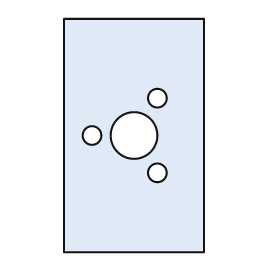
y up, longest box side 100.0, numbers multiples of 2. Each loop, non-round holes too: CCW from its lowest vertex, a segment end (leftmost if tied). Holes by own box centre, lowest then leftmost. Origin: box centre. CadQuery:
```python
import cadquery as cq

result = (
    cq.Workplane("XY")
    .moveTo(-30.0, -50.0)
    .lineTo(30.0, -50.0)
    .lineTo(30.0, 50.0)
    .lineTo(-30.0, 50.0)
    .close()
    .moveTo(10.0, -16.0)
    .circle(4.0)
    .moveTo(-18.0, 0.0)
    .circle(4.0)
    .moveTo(0.0, 0.0)
    .circle(10.0)
    .moveTo(10.0, 16.0)
    .circle(4.0)
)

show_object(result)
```